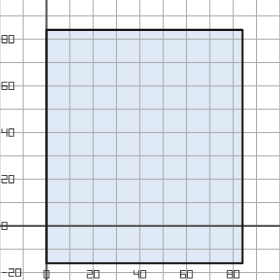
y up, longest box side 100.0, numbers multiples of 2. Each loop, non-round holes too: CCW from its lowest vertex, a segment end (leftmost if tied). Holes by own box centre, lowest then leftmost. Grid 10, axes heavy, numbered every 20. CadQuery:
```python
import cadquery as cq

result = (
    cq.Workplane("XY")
    .moveTo(0.0, -16.0)
    .lineTo(84.0, -16.0)
    .lineTo(84.0, 84.0)
    .lineTo(0.0, 84.0)
    .close()
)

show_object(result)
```